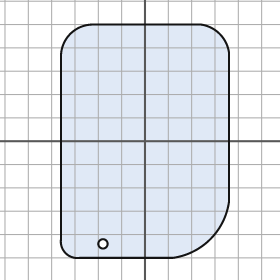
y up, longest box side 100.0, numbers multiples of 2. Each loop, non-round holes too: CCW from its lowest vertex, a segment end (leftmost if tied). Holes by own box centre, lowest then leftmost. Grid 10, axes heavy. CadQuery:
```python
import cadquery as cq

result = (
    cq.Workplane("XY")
    .moveTo(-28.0, -50.0)
    .lineTo(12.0, -50.0)
    .threePointArc((28.0, -42.0), (36.0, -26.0))
    .lineTo(36.0, 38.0)
    .threePointArc((32.0, 46.0), (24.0, 50.0))
    .lineTo(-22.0, 50.0)
    .threePointArc((-32.0, 46.0), (-36.0, 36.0))
    .lineTo(-36.0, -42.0)
    .threePointArc((-34.0, -48.0), (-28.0, -50.0))
    .close()
    .moveTo(-18.0, -44.0)
    .circle(2.0)
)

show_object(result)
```